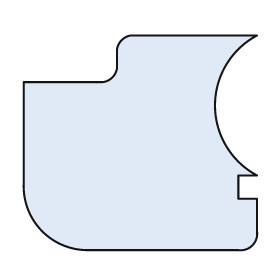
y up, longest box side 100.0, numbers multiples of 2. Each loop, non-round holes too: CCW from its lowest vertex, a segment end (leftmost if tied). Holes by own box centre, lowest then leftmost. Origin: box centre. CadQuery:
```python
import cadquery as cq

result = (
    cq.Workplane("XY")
    .moveTo(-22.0, -46.0)
    .lineTo(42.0, -46.0)
    .threePointArc((48.0, -44.0), (50.0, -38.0))
    .lineTo(50.0, -24.0)
    .lineTo(42.0, -24.0)
    .lineTo(42.0, -14.0)
    .lineTo(50.0, -14.0)
    .threePointArc((32.0, 16.0), (50.0, 46.0))
    .lineTo(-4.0, 46.0)
    .threePointArc((-8.0, 44.0), (-10.0, 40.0))
    .lineTo(-10.0, 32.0)
    .threePointArc((-12.0, 28.0), (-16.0, 26.0))
    .lineTo(-50.0, 26.0)
    .lineTo(-50.0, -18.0)
    .threePointArc((-42.0, -38.0), (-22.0, -46.0))
    .close()
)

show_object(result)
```